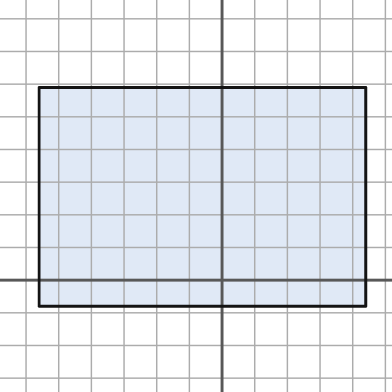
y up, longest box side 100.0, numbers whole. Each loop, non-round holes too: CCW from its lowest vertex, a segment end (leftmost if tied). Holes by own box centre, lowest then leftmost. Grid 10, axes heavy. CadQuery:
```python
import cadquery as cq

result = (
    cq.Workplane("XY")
    .moveTo(-56.0, -8.0)
    .lineTo(44.0, -8.0)
    .lineTo(44.0, 59.0)
    .lineTo(-56.0, 59.0)
    .close()
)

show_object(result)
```